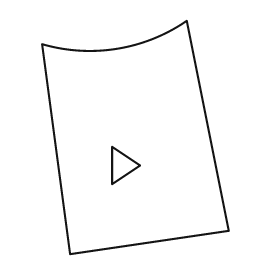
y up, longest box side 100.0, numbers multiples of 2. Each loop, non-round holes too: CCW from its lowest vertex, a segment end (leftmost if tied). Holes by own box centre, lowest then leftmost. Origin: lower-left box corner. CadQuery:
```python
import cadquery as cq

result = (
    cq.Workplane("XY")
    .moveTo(12.0, 0.0)
    .lineTo(80.0, 10.0)
    .lineTo(62.0, 100.0)
    .threePointArc((32.0, 88.0), (0.0, 90.0))
    .close()
    .moveTo(30.0, 30.0)
    .lineTo(42.0, 38.0)
    .lineTo(30.0, 46.0)
    .close()
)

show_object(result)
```